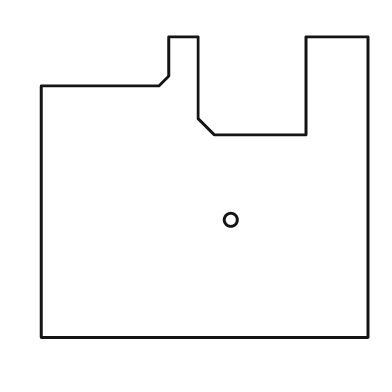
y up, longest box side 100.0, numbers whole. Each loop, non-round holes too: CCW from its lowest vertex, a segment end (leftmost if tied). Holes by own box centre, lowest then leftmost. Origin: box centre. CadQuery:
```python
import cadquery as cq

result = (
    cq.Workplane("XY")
    .moveTo(-50.0, -46.0)
    .lineTo(50.0, -46.0)
    .lineTo(50.0, 46.0)
    .lineTo(31.0, 46.0)
    .lineTo(31.0, 16.0)
    .lineTo(3.0, 16.0)
    .lineTo(-2.0, 21.0)
    .lineTo(-2.0, 46.0)
    .lineTo(-11.0, 46.0)
    .lineTo(-11.0, 34.0)
    .lineTo(-14.0, 31.0)
    .lineTo(-50.0, 31.0)
    .close()
    .moveTo(8.0, -10.0)
    .circle(2.0)
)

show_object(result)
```